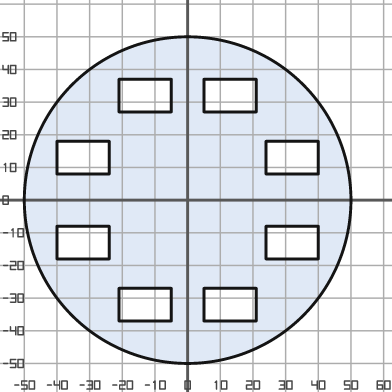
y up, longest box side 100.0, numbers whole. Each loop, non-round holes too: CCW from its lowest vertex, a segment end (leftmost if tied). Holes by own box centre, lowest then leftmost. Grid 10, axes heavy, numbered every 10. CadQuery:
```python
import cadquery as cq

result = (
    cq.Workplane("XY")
    .moveTo(0.0, 0.0)
    .circle(50.0)
    .moveTo(-21.0, -37.0)
    .lineTo(-5.0, -37.0)
    .lineTo(-5.0, -27.0)
    .lineTo(-21.0, -27.0)
    .close()
    .moveTo(5.0, -37.0)
    .lineTo(21.0, -37.0)
    .lineTo(21.0, -27.0)
    .lineTo(5.0, -27.0)
    .close()
    .moveTo(-40.0, -18.0)
    .lineTo(-24.0, -18.0)
    .lineTo(-24.0, -8.0)
    .lineTo(-40.0, -8.0)
    .close()
    .moveTo(24.0, -18.0)
    .lineTo(40.0, -18.0)
    .lineTo(40.0, -8.0)
    .lineTo(24.0, -8.0)
    .close()
    .moveTo(-40.0, 8.0)
    .lineTo(-24.0, 8.0)
    .lineTo(-24.0, 18.0)
    .lineTo(-40.0, 18.0)
    .close()
    .moveTo(24.0, 8.0)
    .lineTo(40.0, 8.0)
    .lineTo(40.0, 18.0)
    .lineTo(24.0, 18.0)
    .close()
    .moveTo(-21.0, 27.0)
    .lineTo(-5.0, 27.0)
    .lineTo(-5.0, 37.0)
    .lineTo(-21.0, 37.0)
    .close()
    .moveTo(5.0, 27.0)
    .lineTo(21.0, 27.0)
    .lineTo(21.0, 37.0)
    .lineTo(5.0, 37.0)
    .close()
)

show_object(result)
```